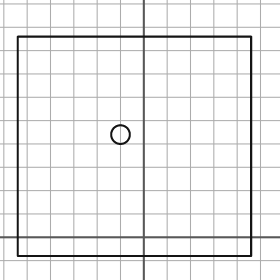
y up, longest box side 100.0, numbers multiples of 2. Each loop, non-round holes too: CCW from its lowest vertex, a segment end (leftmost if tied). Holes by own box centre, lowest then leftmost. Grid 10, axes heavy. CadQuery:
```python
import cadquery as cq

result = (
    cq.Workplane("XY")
    .moveTo(-54.0, -8.0)
    .lineTo(46.0, -8.0)
    .lineTo(46.0, 86.0)
    .lineTo(-54.0, 86.0)
    .close()
    .moveTo(-10.0, 44.0)
    .circle(4.0)
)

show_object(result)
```